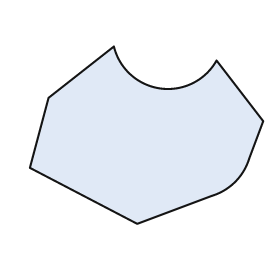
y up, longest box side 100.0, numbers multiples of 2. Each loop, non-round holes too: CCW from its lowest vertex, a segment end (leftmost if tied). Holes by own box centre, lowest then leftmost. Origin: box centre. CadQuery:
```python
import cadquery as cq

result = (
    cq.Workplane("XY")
    .moveTo(-4.0, -38.0)
    .lineTo(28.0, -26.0)
    .threePointArc((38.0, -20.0), (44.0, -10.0))
    .lineTo(50.0, 6.0)
    .lineTo(30.0, 32.0)
    .threePointArc((6.0, 20.0), (-14.0, 38.0))
    .lineTo(-42.0, 16.0)
    .lineTo(-50.0, -14.0)
    .close()
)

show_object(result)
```